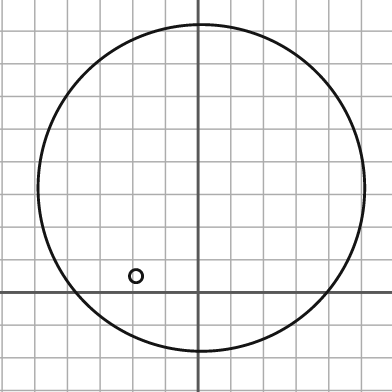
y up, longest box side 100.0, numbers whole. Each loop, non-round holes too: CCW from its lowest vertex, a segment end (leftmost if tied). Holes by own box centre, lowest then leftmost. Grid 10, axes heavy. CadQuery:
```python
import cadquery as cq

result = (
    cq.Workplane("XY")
    .moveTo(1.0, 32.0)
    .circle(50.0)
    .moveTo(-19.0, 5.0)
    .circle(2.0)
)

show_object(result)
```